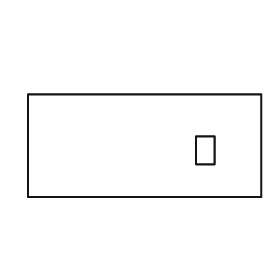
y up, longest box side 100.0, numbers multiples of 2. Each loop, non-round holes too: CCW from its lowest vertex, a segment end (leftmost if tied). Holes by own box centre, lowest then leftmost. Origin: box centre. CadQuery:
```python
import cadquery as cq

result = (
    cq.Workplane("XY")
    .moveTo(-50.0, -22.0)
    .lineTo(50.0, -22.0)
    .lineTo(50.0, 22.0)
    .lineTo(-50.0, 22.0)
    .close()
    .moveTo(22.0, -8.0)
    .lineTo(30.0, -8.0)
    .lineTo(30.0, 4.0)
    .lineTo(22.0, 4.0)
    .close()
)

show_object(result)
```